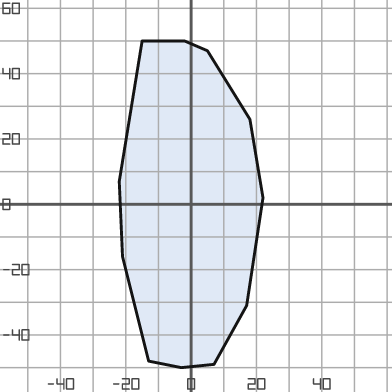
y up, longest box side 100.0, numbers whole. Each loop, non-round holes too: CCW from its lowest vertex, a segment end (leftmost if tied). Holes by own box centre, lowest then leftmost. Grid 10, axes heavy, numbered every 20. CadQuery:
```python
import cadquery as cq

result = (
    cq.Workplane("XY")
    .moveTo(-3.0, -50.0)
    .lineTo(7.0, -49.0)
    .lineTo(17.0, -31.0)
    .lineTo(22.0, 2.0)
    .lineTo(18.0, 26.0)
    .lineTo(5.0, 47.0)
    .lineTo(-2.0, 50.0)
    .lineTo(-15.0, 50.0)
    .lineTo(-22.0, 7.0)
    .lineTo(-21.0, -16.0)
    .lineTo(-13.0, -48.0)
    .close()
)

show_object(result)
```